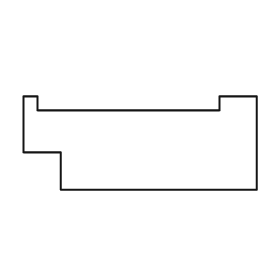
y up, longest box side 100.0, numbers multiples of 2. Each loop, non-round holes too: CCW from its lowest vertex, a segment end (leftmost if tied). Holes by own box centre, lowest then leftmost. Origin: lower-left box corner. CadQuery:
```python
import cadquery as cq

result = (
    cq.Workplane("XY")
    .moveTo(16.0, 0.0)
    .lineTo(100.0, 0.0)
    .lineTo(100.0, 40.0)
    .lineTo(84.0, 40.0)
    .lineTo(84.0, 34.0)
    .lineTo(6.0, 34.0)
    .lineTo(6.0, 40.0)
    .lineTo(0.0, 40.0)
    .lineTo(0.0, 16.0)
    .lineTo(16.0, 16.0)
    .close()
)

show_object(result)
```